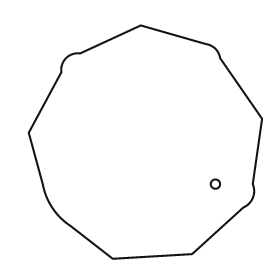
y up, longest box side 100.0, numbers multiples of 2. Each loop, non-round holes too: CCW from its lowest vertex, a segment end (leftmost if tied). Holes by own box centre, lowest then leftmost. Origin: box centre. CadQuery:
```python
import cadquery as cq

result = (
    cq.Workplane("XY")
    .moveTo(-14.0, -50.0)
    .lineTo(20.0, -48.0)
    .lineTo(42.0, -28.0)
    .threePointArc((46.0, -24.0), (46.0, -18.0))
    .lineTo(50.0, 10.0)
    .lineTo(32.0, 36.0)
    .threePointArc((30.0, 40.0), (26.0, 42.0))
    .lineTo(-2.0, 50.0)
    .lineTo(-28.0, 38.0)
    .threePointArc((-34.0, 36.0), (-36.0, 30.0))
    .lineTo(-50.0, 4.0)
    .lineTo(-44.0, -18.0)
    .threePointArc((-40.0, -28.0), (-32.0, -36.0))
    .close()
    .moveTo(30.0, -18.0)
    .circle(2.0)
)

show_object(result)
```